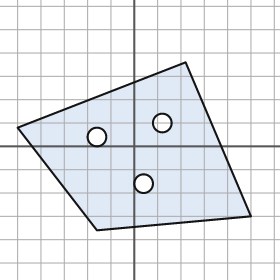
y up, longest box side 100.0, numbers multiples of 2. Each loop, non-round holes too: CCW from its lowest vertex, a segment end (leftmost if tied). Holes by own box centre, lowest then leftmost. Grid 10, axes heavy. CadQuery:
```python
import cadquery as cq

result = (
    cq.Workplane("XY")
    .moveTo(-16.0, -36.0)
    .lineTo(50.0, -30.0)
    .lineTo(22.0, 36.0)
    .lineTo(-50.0, 8.0)
    .close()
    .moveTo(4.0, -16.0)
    .circle(4.0)
    .moveTo(-16.0, 4.0)
    .circle(4.0)
    .moveTo(12.0, 10.0)
    .circle(4.0)
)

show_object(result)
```